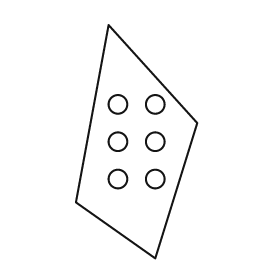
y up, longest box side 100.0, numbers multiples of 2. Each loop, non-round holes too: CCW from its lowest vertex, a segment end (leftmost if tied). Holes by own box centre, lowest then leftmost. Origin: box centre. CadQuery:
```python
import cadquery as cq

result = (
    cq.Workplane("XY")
    .moveTo(8.0, -50.0)
    .lineTo(26.0, 8.0)
    .lineTo(-12.0, 50.0)
    .lineTo(-26.0, -26.0)
    .close()
    .moveTo(-8.0, -16.0)
    .circle(4.0)
    .moveTo(8.0, -16.0)
    .circle(4.0)
    .moveTo(-8.0, 0.0)
    .circle(4.0)
    .moveTo(8.0, 0.0)
    .circle(4.0)
    .moveTo(-8.0, 16.0)
    .circle(4.0)
    .moveTo(8.0, 16.0)
    .circle(4.0)
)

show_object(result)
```